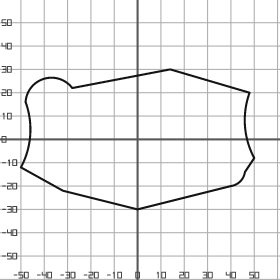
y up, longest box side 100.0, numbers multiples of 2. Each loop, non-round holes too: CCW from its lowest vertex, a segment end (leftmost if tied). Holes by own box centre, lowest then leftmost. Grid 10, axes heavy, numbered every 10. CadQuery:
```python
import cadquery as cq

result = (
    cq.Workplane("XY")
    .moveTo(0.0, -30.0)
    .lineTo(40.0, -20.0)
    .threePointArc((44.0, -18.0), (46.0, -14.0))
    .lineTo(50.0, -8.0)
    .threePointArc((46.0, 6.0), (48.0, 20.0))
    .lineTo(14.0, 30.0)
    .lineTo(-28.0, 22.0)
    .threePointArc((-40.0, 26.0), (-48.0, 16.0))
    .threePointArc((-46.0, 2.0), (-50.0, -12.0))
    .lineTo(-32.0, -22.0)
    .close()
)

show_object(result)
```